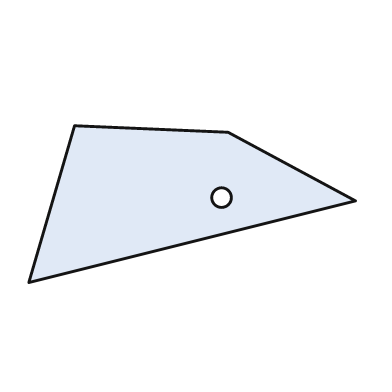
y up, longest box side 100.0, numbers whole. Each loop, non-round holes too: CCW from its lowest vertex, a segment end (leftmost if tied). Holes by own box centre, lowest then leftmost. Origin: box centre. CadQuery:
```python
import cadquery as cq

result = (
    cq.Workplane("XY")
    .moveTo(-50.0, -24.0)
    .lineTo(50.0, 1.0)
    .lineTo(11.0, 22.0)
    .lineTo(-36.0, 24.0)
    .close()
    .moveTo(9.0, 2.0)
    .circle(3.0)
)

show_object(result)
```